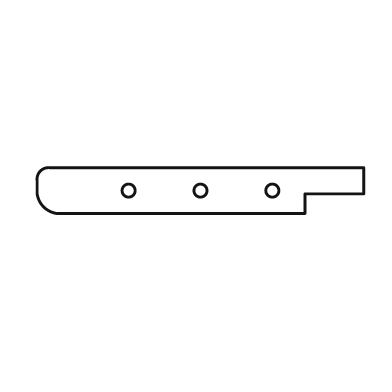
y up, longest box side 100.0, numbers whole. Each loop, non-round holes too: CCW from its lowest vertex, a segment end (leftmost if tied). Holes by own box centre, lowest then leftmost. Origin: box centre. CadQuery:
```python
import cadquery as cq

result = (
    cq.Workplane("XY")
    .moveTo(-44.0, -7.0)
    .lineTo(32.0, -7.0)
    .lineTo(32.0, -1.0)
    .lineTo(50.0, -1.0)
    .lineTo(50.0, 7.0)
    .lineTo(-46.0, 7.0)
    .threePointArc((-49.0, 6.0), (-50.0, 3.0))
    .lineTo(-50.0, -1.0)
    .threePointArc((-48.0, -5.0), (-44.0, -7.0))
    .close()
    .moveTo(-22.0, 0.0)
    .circle(2.0)
    .moveTo(0.0, 0.0)
    .circle(2.0)
    .moveTo(22.0, 0.0)
    .circle(2.0)
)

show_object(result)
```